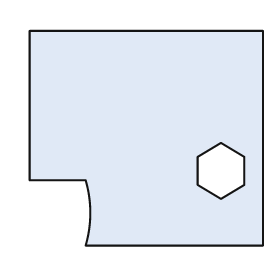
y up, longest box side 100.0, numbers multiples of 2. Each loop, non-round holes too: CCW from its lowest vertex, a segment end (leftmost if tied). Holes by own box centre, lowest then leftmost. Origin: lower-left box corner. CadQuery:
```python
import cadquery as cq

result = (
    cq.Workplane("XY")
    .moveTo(24.0, 0.0)
    .lineTo(100.0, 0.0)
    .lineTo(100.0, 92.0)
    .lineTo(0.0, 92.0)
    .lineTo(0.0, 28.0)
    .lineTo(24.0, 28.0)
    .threePointArc((26.0, 14.0), (24.0, 0.0))
    .close()
    .moveTo(82.0, 20.0)
    .lineTo(92.0, 26.0)
    .lineTo(92.0, 38.0)
    .lineTo(82.0, 44.0)
    .lineTo(72.0, 38.0)
    .lineTo(72.0, 26.0)
    .close()
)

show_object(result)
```